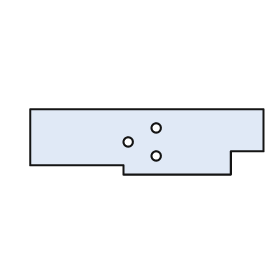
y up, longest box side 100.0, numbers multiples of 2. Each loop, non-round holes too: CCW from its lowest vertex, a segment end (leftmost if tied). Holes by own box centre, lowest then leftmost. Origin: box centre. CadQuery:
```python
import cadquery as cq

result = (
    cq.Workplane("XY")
    .moveTo(-10.0, -14.0)
    .lineTo(36.0, -14.0)
    .lineTo(36.0, -4.0)
    .lineTo(50.0, -4.0)
    .lineTo(50.0, 14.0)
    .lineTo(-50.0, 14.0)
    .lineTo(-50.0, -10.0)
    .lineTo(-10.0, -10.0)
    .close()
    .moveTo(4.0, -6.0)
    .circle(2.0)
    .moveTo(-8.0, 0.0)
    .circle(2.0)
    .moveTo(4.0, 6.0)
    .circle(2.0)
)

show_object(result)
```